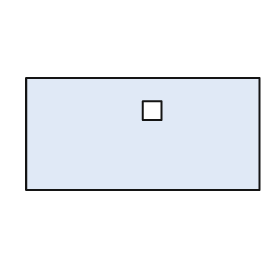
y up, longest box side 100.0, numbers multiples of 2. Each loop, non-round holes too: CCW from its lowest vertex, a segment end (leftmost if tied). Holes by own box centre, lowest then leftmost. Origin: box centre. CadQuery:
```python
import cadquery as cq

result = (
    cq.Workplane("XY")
    .moveTo(-50.0, -24.0)
    .lineTo(50.0, -24.0)
    .lineTo(50.0, 24.0)
    .lineTo(-50.0, 24.0)
    .close()
    .moveTo(0.0, 6.0)
    .lineTo(8.0, 6.0)
    .lineTo(8.0, 14.0)
    .lineTo(0.0, 14.0)
    .close()
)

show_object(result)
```